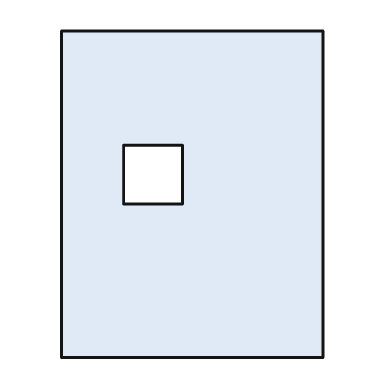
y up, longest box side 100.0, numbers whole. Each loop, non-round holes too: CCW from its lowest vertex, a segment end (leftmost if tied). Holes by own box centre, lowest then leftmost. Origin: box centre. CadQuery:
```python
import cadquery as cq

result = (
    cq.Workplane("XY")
    .moveTo(-40.0, -50.0)
    .lineTo(40.0, -50.0)
    .lineTo(40.0, 50.0)
    .lineTo(-40.0, 50.0)
    .close()
    .moveTo(-21.0, -3.0)
    .lineTo(-3.0, -3.0)
    .lineTo(-3.0, 15.0)
    .lineTo(-21.0, 15.0)
    .close()
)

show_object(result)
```